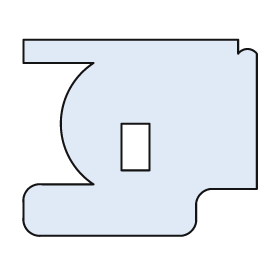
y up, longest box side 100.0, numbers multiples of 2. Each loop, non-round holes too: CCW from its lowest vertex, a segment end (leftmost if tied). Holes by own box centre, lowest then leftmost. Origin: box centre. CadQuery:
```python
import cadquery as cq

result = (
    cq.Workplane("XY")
    .moveTo(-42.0, -42.0)
    .lineTo(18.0, -42.0)
    .threePointArc((22.0, -40.0), (24.0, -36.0))
    .lineTo(24.0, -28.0)
    .threePointArc((26.0, -24.0), (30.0, -22.0))
    .lineTo(50.0, -22.0)
    .lineTo(50.0, 36.0)
    .threePointArc((46.0, 38.0), (42.0, 36.0))
    .lineTo(42.0, 42.0)
    .lineTo(-50.0, 42.0)
    .lineTo(-50.0, 32.0)
    .lineTo(-20.0, 32.0)
    .threePointArc((-34.0, 6.0), (-20.0, -20.0))
    .lineTo(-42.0, -20.0)
    .threePointArc((-48.0, -22.0), (-50.0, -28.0))
    .lineTo(-50.0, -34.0)
    .threePointArc((-48.0, -40.0), (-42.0, -42.0))
    .close()
    .moveTo(-8.0, -14.0)
    .lineTo(4.0, -14.0)
    .lineTo(4.0, 6.0)
    .lineTo(-8.0, 6.0)
    .close()
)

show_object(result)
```